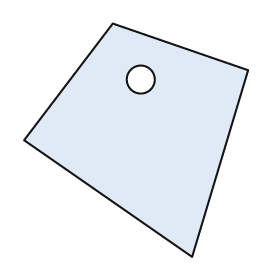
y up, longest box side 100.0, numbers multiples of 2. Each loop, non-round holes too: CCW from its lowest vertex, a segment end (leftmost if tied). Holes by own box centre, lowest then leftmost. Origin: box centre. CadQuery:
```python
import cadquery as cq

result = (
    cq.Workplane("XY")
    .moveTo(24.0, -50.0)
    .lineTo(48.0, 30.0)
    .lineTo(-10.0, 50.0)
    .lineTo(-48.0, 0.0)
    .close()
    .moveTo(2.0, 26.0)
    .circle(6.0)
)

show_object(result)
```